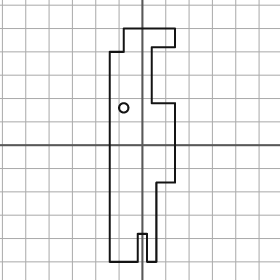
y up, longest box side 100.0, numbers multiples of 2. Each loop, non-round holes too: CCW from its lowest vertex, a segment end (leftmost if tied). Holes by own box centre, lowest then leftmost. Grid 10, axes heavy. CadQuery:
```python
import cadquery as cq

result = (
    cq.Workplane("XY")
    .moveTo(-14.0, -50.0)
    .lineTo(-2.0, -50.0)
    .lineTo(-2.0, -38.0)
    .lineTo(2.0, -38.0)
    .lineTo(2.0, -50.0)
    .lineTo(6.0, -50.0)
    .lineTo(6.0, -16.0)
    .lineTo(14.0, -16.0)
    .lineTo(14.0, 18.0)
    .lineTo(4.0, 18.0)
    .lineTo(4.0, 42.0)
    .lineTo(14.0, 42.0)
    .lineTo(14.0, 50.0)
    .lineTo(-8.0, 50.0)
    .lineTo(-8.0, 40.0)
    .lineTo(-14.0, 40.0)
    .close()
    .moveTo(-8.0, 16.0)
    .circle(2.0)
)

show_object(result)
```